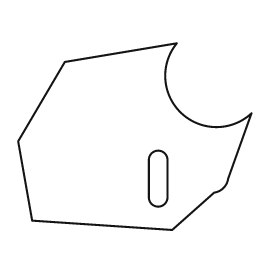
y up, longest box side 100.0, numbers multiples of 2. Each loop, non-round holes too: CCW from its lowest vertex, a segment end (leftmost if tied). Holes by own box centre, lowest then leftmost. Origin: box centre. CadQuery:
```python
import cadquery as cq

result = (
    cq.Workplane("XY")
    .moveTo(16.0, -40.0)
    .lineTo(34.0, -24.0)
    .threePointArc((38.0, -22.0), (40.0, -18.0))
    .lineTo(50.0, 10.0)
    .threePointArc((20.0, 10.0), (18.0, 40.0))
    .lineTo(-30.0, 32.0)
    .lineTo(-50.0, -2.0)
    .lineTo(-44.0, -36.0)
    .close()
    .moveTo(6.0, -26.0)
    .threePointArc((10.0, -30.0), (14.0, -26.0))
    .lineTo(14.0, -10.0)
    .threePointArc((10.0, -6.0), (6.0, -10.0))
    .close()
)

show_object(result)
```